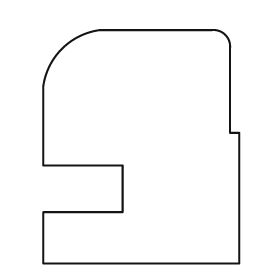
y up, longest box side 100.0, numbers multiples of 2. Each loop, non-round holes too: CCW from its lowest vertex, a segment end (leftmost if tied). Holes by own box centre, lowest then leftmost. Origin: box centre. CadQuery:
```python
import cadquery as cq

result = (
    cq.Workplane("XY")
    .moveTo(-42.0, -50.0)
    .lineTo(42.0, -50.0)
    .lineTo(42.0, 6.0)
    .lineTo(38.0, 6.0)
    .lineTo(38.0, 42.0)
    .threePointArc((36.0, 48.0), (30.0, 50.0))
    .lineTo(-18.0, 50.0)
    .threePointArc((-34.0, 42.0), (-42.0, 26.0))
    .lineTo(-42.0, -8.0)
    .lineTo(-8.0, -8.0)
    .lineTo(-8.0, -28.0)
    .lineTo(-42.0, -28.0)
    .close()
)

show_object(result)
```